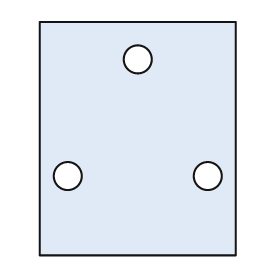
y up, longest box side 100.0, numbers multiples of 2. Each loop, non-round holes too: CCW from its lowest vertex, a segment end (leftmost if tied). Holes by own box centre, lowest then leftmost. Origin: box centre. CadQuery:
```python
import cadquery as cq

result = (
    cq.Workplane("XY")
    .moveTo(-42.0, -50.0)
    .lineTo(42.0, -50.0)
    .lineTo(42.0, 50.0)
    .lineTo(-42.0, 50.0)
    .close()
    .moveTo(-30.0, -16.0)
    .circle(6.0)
    .moveTo(30.0, -16.0)
    .circle(6.0)
    .moveTo(0.0, 34.0)
    .circle(6.0)
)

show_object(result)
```